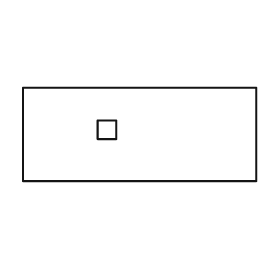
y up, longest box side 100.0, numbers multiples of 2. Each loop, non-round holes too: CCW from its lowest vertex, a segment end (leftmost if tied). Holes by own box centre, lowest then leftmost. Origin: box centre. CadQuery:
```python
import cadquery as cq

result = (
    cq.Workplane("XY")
    .moveTo(-50.0, -20.0)
    .lineTo(50.0, -20.0)
    .lineTo(50.0, 20.0)
    .lineTo(-50.0, 20.0)
    .close()
    .moveTo(-18.0, -2.0)
    .lineTo(-10.0, -2.0)
    .lineTo(-10.0, 6.0)
    .lineTo(-18.0, 6.0)
    .close()
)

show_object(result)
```